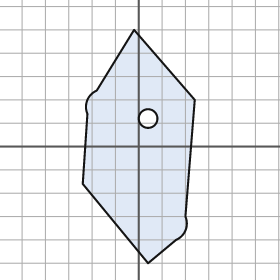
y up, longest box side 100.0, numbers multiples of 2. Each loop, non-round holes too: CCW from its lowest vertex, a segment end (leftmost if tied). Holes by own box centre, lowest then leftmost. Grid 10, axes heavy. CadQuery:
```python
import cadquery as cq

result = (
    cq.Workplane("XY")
    .moveTo(4.0, -50.0)
    .lineTo(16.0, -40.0)
    .threePointArc((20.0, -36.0), (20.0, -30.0))
    .lineTo(24.0, 20.0)
    .lineTo(-2.0, 50.0)
    .lineTo(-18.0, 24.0)
    .threePointArc((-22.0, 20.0), (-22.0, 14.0))
    .lineTo(-24.0, -16.0)
    .close()
    .moveTo(4.0, 12.0)
    .circle(4.0)
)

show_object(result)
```